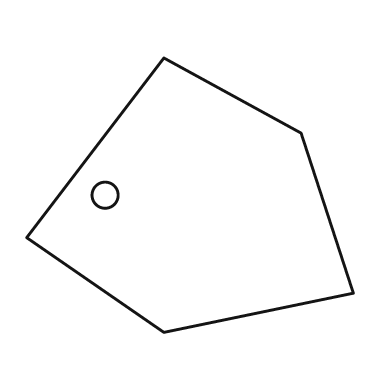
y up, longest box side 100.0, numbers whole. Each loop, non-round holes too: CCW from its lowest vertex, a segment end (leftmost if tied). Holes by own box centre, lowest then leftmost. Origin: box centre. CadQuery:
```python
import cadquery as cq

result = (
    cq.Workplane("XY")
    .moveTo(-8.0, -42.0)
    .lineTo(50.0, -30.0)
    .lineTo(34.0, 19.0)
    .lineTo(-8.0, 42.0)
    .lineTo(-50.0, -13.0)
    .close()
    .moveTo(-26.0, 0.0)
    .circle(4.0)
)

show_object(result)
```